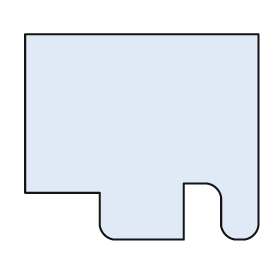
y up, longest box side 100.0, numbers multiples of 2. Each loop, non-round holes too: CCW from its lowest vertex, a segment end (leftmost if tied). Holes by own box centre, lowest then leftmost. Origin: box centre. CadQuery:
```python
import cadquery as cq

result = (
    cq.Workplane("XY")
    .moveTo(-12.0, -44.0)
    .lineTo(18.0, -44.0)
    .lineTo(18.0, -20.0)
    .lineTo(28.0, -20.0)
    .threePointArc((32.0, -22.0), (34.0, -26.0))
    .lineTo(34.0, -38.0)
    .threePointArc((36.0, -42.0), (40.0, -44.0))
    .lineTo(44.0, -44.0)
    .threePointArc((48.0, -42.0), (50.0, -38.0))
    .lineTo(50.0, 44.0)
    .lineTo(-50.0, 44.0)
    .lineTo(-50.0, -24.0)
    .lineTo(-18.0, -24.0)
    .lineTo(-18.0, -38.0)
    .threePointArc((-16.0, -42.0), (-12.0, -44.0))
    .close()
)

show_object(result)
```